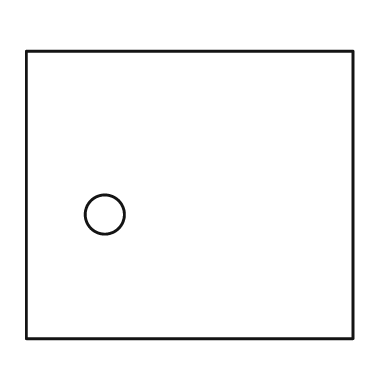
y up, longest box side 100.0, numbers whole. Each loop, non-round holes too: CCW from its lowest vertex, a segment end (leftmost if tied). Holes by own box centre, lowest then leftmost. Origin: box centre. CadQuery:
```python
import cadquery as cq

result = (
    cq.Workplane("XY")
    .moveTo(-50.0, -44.0)
    .lineTo(50.0, -44.0)
    .lineTo(50.0, 44.0)
    .lineTo(-50.0, 44.0)
    .close()
    .moveTo(-26.0, -6.0)
    .circle(6.0)
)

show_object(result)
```